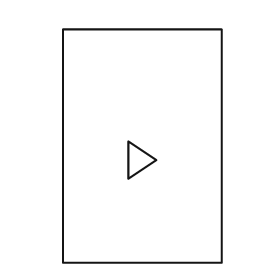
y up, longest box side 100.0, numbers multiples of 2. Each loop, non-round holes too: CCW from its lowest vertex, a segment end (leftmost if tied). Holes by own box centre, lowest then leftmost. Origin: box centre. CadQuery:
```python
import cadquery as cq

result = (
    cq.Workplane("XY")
    .moveTo(-34.0, -50.0)
    .lineTo(34.0, -50.0)
    .lineTo(34.0, 50.0)
    .lineTo(-34.0, 50.0)
    .close()
    .moveTo(-6.0, -14.0)
    .lineTo(6.0, -6.0)
    .lineTo(-6.0, 2.0)
    .close()
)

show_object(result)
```